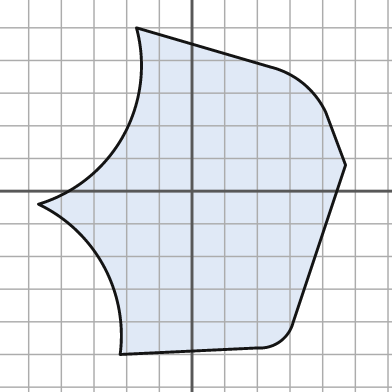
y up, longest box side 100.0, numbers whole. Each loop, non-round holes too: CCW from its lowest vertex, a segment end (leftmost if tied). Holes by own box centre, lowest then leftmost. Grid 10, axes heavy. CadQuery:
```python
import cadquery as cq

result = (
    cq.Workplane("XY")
    .moveTo(-22.0, -50.0)
    .lineTo(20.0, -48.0)
    .threePointArc((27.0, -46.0), (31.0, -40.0))
    .lineTo(47.0, 8.0)
    .lineTo(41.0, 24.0)
    .threePointArc((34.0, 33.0), (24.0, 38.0))
    .lineTo(-17.0, 50.0)
    .threePointArc((-21.0, 17.0), (-47.0, -4.0))
    .threePointArc((-27.0, -23.0), (-22.0, -50.0))
    .close()
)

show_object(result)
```